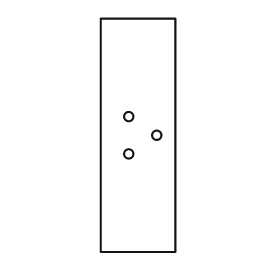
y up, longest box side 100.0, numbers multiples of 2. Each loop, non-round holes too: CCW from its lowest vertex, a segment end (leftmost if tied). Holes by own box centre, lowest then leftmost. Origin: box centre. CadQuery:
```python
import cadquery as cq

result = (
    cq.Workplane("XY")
    .moveTo(-16.0, -50.0)
    .lineTo(16.0, -50.0)
    .lineTo(16.0, 50.0)
    .lineTo(-16.0, 50.0)
    .close()
    .moveTo(-4.0, -8.0)
    .circle(2.0)
    .moveTo(8.0, 0.0)
    .circle(2.0)
    .moveTo(-4.0, 8.0)
    .circle(2.0)
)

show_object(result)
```